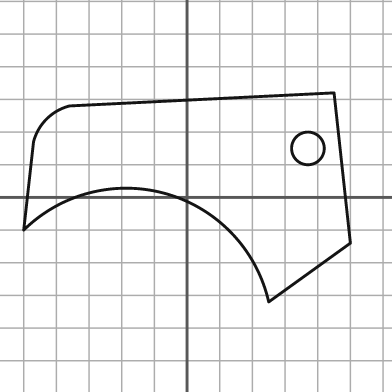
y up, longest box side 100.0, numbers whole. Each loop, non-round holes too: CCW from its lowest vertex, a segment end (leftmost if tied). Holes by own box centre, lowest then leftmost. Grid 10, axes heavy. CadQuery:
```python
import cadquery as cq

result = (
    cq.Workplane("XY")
    .moveTo(25.0, -32.0)
    .lineTo(50.0, -14.0)
    .lineTo(45.0, 32.0)
    .lineTo(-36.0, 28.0)
    .threePointArc((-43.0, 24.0), (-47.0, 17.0))
    .lineTo(-50.0, -10.0)
    .threePointArc((-6.0, 1.0), (25.0, -32.0))
    .close()
    .moveTo(37.0, 15.0)
    .circle(5.0)
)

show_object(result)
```